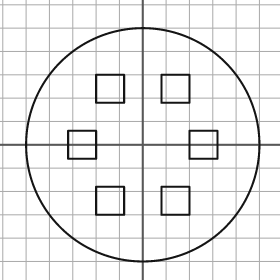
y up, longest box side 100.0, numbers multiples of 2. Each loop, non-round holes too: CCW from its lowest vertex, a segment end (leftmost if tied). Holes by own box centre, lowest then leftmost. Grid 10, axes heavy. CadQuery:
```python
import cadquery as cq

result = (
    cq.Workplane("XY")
    .moveTo(0.0, 0.0)
    .circle(50.0)
    .moveTo(-20.0, -30.0)
    .lineTo(-8.0, -30.0)
    .lineTo(-8.0, -18.0)
    .lineTo(-20.0, -18.0)
    .close()
    .moveTo(8.0, -30.0)
    .lineTo(20.0, -30.0)
    .lineTo(20.0, -18.0)
    .lineTo(8.0, -18.0)
    .close()
    .moveTo(-32.0, -6.0)
    .lineTo(-20.0, -6.0)
    .lineTo(-20.0, 6.0)
    .lineTo(-32.0, 6.0)
    .close()
    .moveTo(20.0, -6.0)
    .lineTo(32.0, -6.0)
    .lineTo(32.0, 6.0)
    .lineTo(20.0, 6.0)
    .close()
    .moveTo(-20.0, 18.0)
    .lineTo(-8.0, 18.0)
    .lineTo(-8.0, 30.0)
    .lineTo(-20.0, 30.0)
    .close()
    .moveTo(8.0, 18.0)
    .lineTo(20.0, 18.0)
    .lineTo(20.0, 30.0)
    .lineTo(8.0, 30.0)
    .close()
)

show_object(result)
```